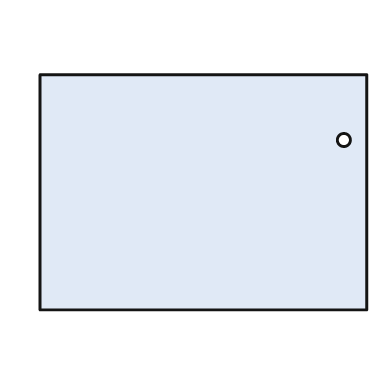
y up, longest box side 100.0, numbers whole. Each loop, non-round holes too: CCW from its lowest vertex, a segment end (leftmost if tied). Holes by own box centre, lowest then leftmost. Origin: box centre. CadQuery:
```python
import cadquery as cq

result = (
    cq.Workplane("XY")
    .moveTo(-50.0, -36.0)
    .lineTo(50.0, -36.0)
    .lineTo(50.0, 36.0)
    .lineTo(-50.0, 36.0)
    .close()
    .moveTo(43.0, 16.0)
    .circle(2.0)
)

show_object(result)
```